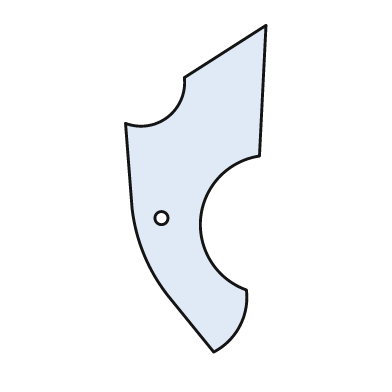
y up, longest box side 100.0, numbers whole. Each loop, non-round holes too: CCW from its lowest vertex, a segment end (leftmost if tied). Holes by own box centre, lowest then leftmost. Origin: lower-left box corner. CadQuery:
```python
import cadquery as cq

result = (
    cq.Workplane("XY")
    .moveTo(27.0, 0.0)
    .threePointArc((35.0, 8.0), (37.0, 19.0))
    .threePointArc((23.0, 41.0), (41.0, 60.0))
    .lineTo(43.0, 100.0)
    .lineTo(18.0, 84.0)
    .threePointArc((13.0, 72.0), (0.0, 70.0))
    .lineTo(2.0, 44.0)
    .threePointArc((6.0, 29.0), (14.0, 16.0))
    .close()
    .moveTo(11.0, 41.0)
    .circle(2.0)
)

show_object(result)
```